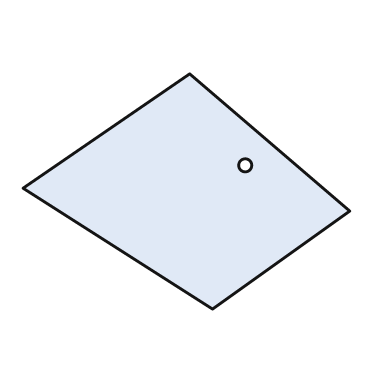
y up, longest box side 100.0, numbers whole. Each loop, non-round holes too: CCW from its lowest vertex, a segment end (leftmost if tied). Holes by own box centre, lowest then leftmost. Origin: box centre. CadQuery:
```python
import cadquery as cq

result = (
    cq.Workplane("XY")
    .moveTo(8.0, -36.0)
    .lineTo(50.0, -6.0)
    .lineTo(1.0, 36.0)
    .lineTo(-50.0, 1.0)
    .close()
    .moveTo(18.0, 8.0)
    .circle(2.0)
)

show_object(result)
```